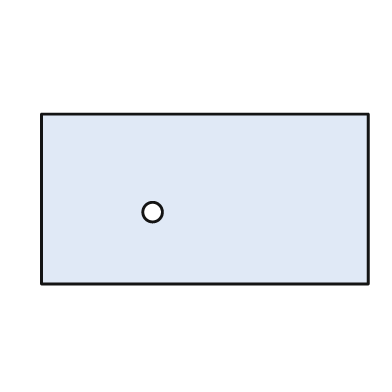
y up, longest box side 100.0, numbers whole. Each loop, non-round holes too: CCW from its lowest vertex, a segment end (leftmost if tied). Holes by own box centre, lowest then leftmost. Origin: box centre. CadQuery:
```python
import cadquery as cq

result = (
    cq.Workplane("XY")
    .moveTo(-50.0, -26.0)
    .lineTo(50.0, -26.0)
    .lineTo(50.0, 26.0)
    .lineTo(-50.0, 26.0)
    .close()
    .moveTo(-16.0, -4.0)
    .circle(3.0)
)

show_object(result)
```